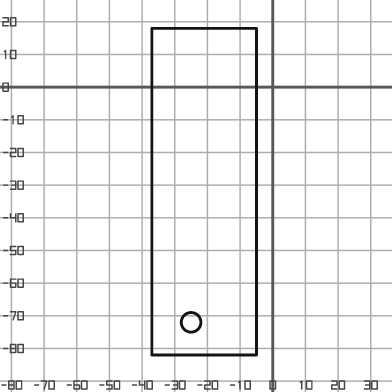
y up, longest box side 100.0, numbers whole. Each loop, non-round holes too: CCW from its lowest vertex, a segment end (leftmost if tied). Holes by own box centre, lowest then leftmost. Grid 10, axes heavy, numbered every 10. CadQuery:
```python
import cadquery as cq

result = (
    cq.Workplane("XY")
    .moveTo(-37.0, -82.0)
    .lineTo(-5.0, -82.0)
    .lineTo(-5.0, 18.0)
    .lineTo(-37.0, 18.0)
    .close()
    .moveTo(-25.0, -72.0)
    .circle(3.0)
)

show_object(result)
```